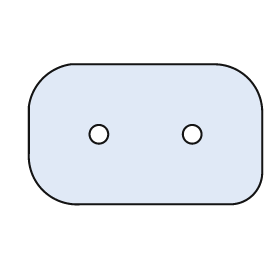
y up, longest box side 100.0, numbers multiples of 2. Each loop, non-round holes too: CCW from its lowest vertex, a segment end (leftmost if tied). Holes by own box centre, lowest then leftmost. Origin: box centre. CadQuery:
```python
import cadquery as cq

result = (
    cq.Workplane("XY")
    .moveTo(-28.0, -30.0)
    .lineTo(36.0, -30.0)
    .threePointArc((46.0, -26.0), (50.0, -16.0))
    .lineTo(50.0, 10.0)
    .threePointArc((44.0, 24.0), (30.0, 30.0))
    .lineTo(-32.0, 30.0)
    .threePointArc((-44.0, 24.0), (-50.0, 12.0))
    .lineTo(-50.0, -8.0)
    .threePointArc((-44.0, -24.0), (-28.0, -30.0))
    .close()
    .moveTo(-20.0, 0.0)
    .circle(4.0)
    .moveTo(20.0, 0.0)
    .circle(4.0)
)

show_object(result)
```